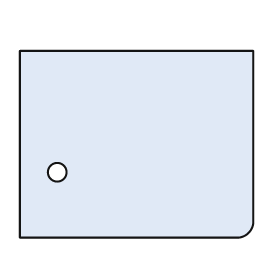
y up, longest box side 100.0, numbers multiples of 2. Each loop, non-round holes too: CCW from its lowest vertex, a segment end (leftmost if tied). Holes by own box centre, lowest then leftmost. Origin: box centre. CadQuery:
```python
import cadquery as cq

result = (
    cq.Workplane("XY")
    .moveTo(-50.0, -40.0)
    .lineTo(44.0, -40.0)
    .threePointArc((48.0, -38.0), (50.0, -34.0))
    .lineTo(50.0, 40.0)
    .lineTo(-50.0, 40.0)
    .close()
    .moveTo(-34.0, -12.0)
    .circle(4.0)
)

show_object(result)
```